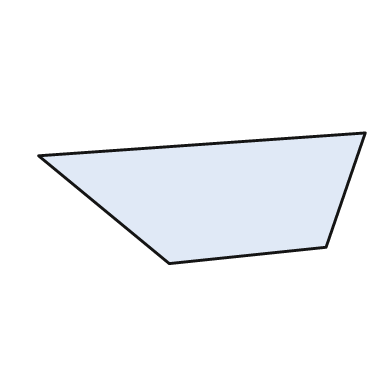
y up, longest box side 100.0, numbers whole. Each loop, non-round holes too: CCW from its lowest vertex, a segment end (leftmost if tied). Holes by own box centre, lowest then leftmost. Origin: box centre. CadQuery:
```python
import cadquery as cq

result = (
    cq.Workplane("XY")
    .moveTo(-10.0, -20.0)
    .lineTo(38.0, -15.0)
    .lineTo(50.0, 20.0)
    .lineTo(-50.0, 13.0)
    .close()
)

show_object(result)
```